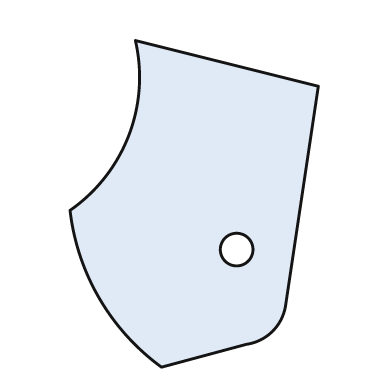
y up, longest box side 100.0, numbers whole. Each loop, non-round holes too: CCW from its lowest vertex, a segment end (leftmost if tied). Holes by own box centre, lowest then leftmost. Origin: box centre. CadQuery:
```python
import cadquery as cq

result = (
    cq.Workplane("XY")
    .moveTo(-10.0, -50.0)
    .lineTo(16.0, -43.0)
    .threePointArc((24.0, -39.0), (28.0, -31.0))
    .lineTo(38.0, 36.0)
    .lineTo(-18.0, 50.0)
    .threePointArc((-20.0, 21.0), (-38.0, -2.0))
    .threePointArc((-29.0, -29.0), (-10.0, -50.0))
    .close()
    .moveTo(13.0, -14.0)
    .circle(5.0)
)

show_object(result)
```